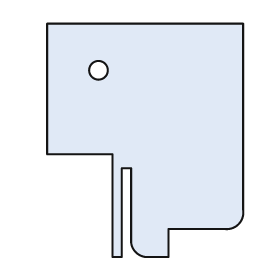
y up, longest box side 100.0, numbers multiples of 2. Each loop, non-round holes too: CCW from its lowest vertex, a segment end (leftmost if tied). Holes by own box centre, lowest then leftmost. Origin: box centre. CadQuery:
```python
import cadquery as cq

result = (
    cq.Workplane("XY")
    .moveTo(-14.0, -50.0)
    .lineTo(-10.0, -50.0)
    .lineTo(-10.0, -12.0)
    .lineTo(-6.0, -12.0)
    .lineTo(-6.0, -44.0)
    .threePointArc((-4.0, -48.0), (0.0, -50.0))
    .lineTo(10.0, -50.0)
    .lineTo(10.0, -38.0)
    .lineTo(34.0, -38.0)
    .threePointArc((40.0, -36.0), (42.0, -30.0))
    .lineTo(42.0, 50.0)
    .lineTo(-42.0, 50.0)
    .lineTo(-42.0, -6.0)
    .lineTo(-14.0, -6.0)
    .close()
    .moveTo(-20.0, 30.0)
    .circle(4.0)
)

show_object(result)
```